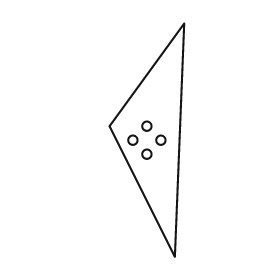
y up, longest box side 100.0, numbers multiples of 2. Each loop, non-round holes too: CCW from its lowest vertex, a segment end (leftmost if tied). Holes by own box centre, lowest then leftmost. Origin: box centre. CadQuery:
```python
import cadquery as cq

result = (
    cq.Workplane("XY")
    .moveTo(12.0, -50.0)
    .lineTo(16.0, 50.0)
    .lineTo(-16.0, 6.0)
    .close()
    .moveTo(0.0, -6.0)
    .circle(2.0)
    .moveTo(-6.0, 0.0)
    .circle(2.0)
    .moveTo(6.0, 0.0)
    .circle(2.0)
    .moveTo(0.0, 6.0)
    .circle(2.0)
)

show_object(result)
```